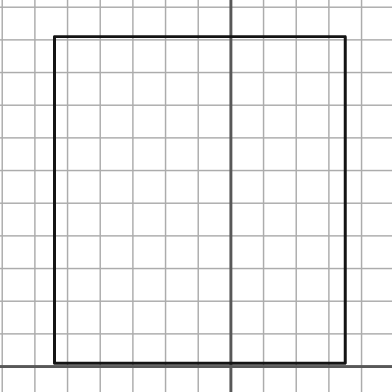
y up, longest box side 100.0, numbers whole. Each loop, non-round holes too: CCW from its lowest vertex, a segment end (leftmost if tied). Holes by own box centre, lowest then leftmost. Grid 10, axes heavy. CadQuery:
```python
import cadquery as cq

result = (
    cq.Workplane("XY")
    .moveTo(-54.0, 1.0)
    .lineTo(35.0, 1.0)
    .lineTo(35.0, 101.0)
    .lineTo(-54.0, 101.0)
    .close()
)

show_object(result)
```